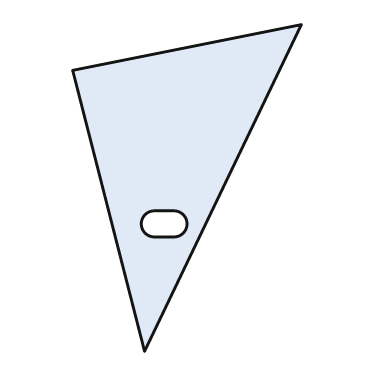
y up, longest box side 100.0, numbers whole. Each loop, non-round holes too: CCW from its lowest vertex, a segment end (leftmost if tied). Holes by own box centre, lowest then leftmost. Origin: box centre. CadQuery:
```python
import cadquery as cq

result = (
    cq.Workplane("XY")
    .moveTo(-13.0, -50.0)
    .lineTo(35.0, 50.0)
    .lineTo(-35.0, 36.0)
    .close()
    .moveTo(-10.0, -15.0)
    .lineTo(-4.0, -15.0)
    .threePointArc((0.0, -11.0), (-4.0, -7.0))
    .lineTo(-10.0, -7.0)
    .threePointArc((-14.0, -11.0), (-10.0, -15.0))
    .close()
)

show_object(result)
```